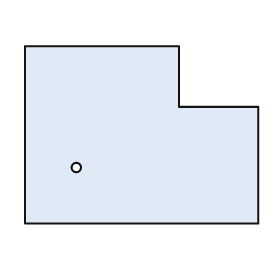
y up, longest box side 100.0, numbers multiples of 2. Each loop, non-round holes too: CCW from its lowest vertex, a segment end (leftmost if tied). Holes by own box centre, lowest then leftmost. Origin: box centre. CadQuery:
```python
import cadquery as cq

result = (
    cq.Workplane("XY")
    .moveTo(-50.0, -38.0)
    .lineTo(50.0, -38.0)
    .lineTo(50.0, 12.0)
    .lineTo(16.0, 12.0)
    .lineTo(16.0, 38.0)
    .lineTo(-50.0, 38.0)
    .close()
    .moveTo(-28.0, -14.0)
    .circle(2.0)
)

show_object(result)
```